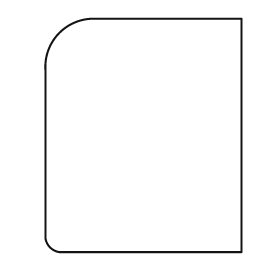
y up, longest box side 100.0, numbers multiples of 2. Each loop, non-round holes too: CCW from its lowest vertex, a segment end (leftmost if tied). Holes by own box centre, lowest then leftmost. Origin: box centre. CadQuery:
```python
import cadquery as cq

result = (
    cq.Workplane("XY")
    .moveTo(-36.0, -50.0)
    .lineTo(42.0, -50.0)
    .lineTo(42.0, 50.0)
    .lineTo(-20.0, 50.0)
    .threePointArc((-36.0, 44.0), (-42.0, 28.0))
    .lineTo(-42.0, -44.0)
    .threePointArc((-40.0, -48.0), (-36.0, -50.0))
    .close()
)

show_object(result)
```